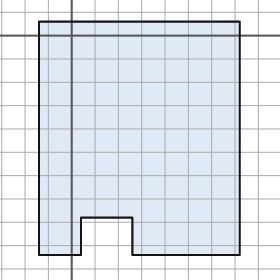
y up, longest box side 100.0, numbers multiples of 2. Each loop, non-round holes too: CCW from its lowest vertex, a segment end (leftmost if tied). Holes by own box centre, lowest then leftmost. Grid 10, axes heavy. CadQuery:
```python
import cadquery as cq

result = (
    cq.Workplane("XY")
    .moveTo(-14.0, -94.0)
    .lineTo(4.0, -94.0)
    .lineTo(4.0, -78.0)
    .lineTo(26.0, -78.0)
    .lineTo(26.0, -94.0)
    .lineTo(72.0, -94.0)
    .lineTo(72.0, 6.0)
    .lineTo(-14.0, 6.0)
    .close()
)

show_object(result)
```